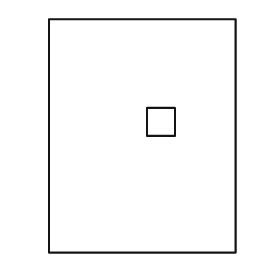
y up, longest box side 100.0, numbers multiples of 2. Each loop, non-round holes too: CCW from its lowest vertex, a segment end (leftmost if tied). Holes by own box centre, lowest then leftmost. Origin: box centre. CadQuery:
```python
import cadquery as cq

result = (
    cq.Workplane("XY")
    .moveTo(-40.0, -50.0)
    .lineTo(40.0, -50.0)
    .lineTo(40.0, 50.0)
    .lineTo(-40.0, 50.0)
    .close()
    .moveTo(2.0, 0.0)
    .lineTo(14.0, 0.0)
    .lineTo(14.0, 12.0)
    .lineTo(2.0, 12.0)
    .close()
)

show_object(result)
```